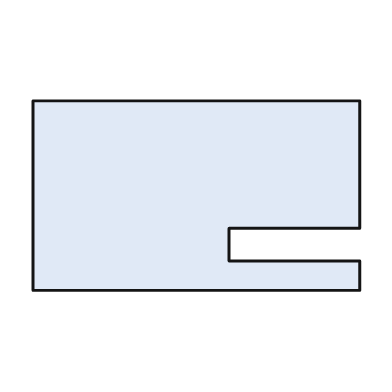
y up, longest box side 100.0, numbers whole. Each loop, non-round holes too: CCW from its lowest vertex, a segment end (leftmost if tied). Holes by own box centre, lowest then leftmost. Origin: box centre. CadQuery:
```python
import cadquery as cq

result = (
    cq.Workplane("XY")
    .moveTo(-50.0, -29.0)
    .lineTo(50.0, -29.0)
    .lineTo(50.0, -20.0)
    .lineTo(10.0, -20.0)
    .lineTo(10.0, -10.0)
    .lineTo(50.0, -10.0)
    .lineTo(50.0, 29.0)
    .lineTo(-50.0, 29.0)
    .close()
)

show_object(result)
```